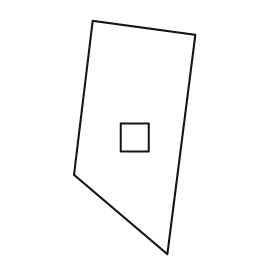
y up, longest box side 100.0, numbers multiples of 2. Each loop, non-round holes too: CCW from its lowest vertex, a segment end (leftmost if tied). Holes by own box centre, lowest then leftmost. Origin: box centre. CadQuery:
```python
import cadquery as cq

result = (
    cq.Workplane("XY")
    .moveTo(14.0, -50.0)
    .lineTo(26.0, 44.0)
    .lineTo(-18.0, 50.0)
    .lineTo(-26.0, -16.0)
    .close()
    .moveTo(-6.0, -6.0)
    .lineTo(6.0, -6.0)
    .lineTo(6.0, 6.0)
    .lineTo(-6.0, 6.0)
    .close()
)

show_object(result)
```